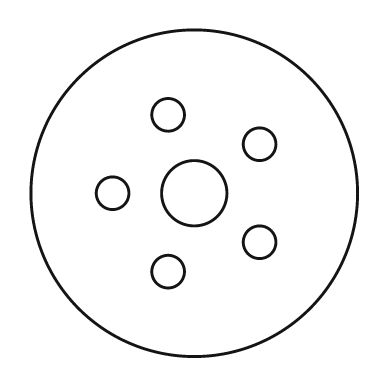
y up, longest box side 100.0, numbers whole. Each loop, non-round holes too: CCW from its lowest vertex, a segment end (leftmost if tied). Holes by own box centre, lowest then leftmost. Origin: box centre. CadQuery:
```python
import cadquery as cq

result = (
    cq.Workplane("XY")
    .moveTo(0.0, 0.0)
    .circle(50.0)
    .moveTo(-8.0, -24.0)
    .circle(5.0)
    .moveTo(20.0, -15.0)
    .circle(5.0)
    .moveTo(-25.0, 0.0)
    .circle(5.0)
    .moveTo(0.0, 0.0)
    .circle(10.0)
    .moveTo(20.0, 15.0)
    .circle(5.0)
    .moveTo(-8.0, 24.0)
    .circle(5.0)
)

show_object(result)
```